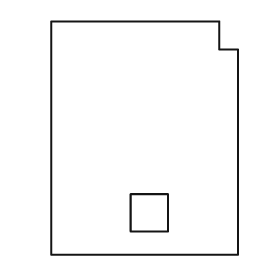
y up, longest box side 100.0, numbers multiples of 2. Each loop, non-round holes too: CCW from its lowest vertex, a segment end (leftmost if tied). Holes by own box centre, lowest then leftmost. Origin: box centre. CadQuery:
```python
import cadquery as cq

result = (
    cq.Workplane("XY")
    .moveTo(-40.0, -50.0)
    .lineTo(40.0, -50.0)
    .lineTo(40.0, 38.0)
    .lineTo(32.0, 38.0)
    .lineTo(32.0, 50.0)
    .lineTo(-40.0, 50.0)
    .close()
    .moveTo(-6.0, -40.0)
    .lineTo(10.0, -40.0)
    .lineTo(10.0, -24.0)
    .lineTo(-6.0, -24.0)
    .close()
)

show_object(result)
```